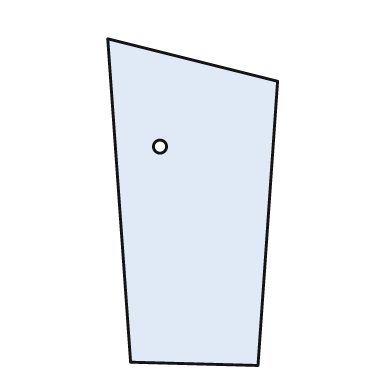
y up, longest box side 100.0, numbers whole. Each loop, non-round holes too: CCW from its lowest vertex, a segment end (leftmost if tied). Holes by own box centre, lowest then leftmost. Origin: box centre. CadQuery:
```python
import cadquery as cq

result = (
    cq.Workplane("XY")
    .moveTo(20.0, -50.0)
    .lineTo(26.0, 37.0)
    .lineTo(-26.0, 50.0)
    .lineTo(-19.0, -49.0)
    .close()
    .moveTo(-10.0, 17.0)
    .circle(2.0)
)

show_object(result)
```